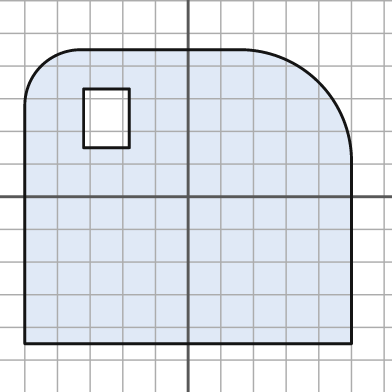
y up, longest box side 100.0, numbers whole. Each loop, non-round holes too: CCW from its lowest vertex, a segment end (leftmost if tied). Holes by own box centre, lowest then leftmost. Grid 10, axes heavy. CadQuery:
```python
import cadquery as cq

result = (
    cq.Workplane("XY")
    .moveTo(-50.0, -45.0)
    .lineTo(50.0, -45.0)
    .lineTo(50.0, 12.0)
    .threePointArc((40.0, 35.0), (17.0, 45.0))
    .lineTo(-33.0, 45.0)
    .threePointArc((-45.0, 40.0), (-50.0, 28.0))
    .close()
    .moveTo(-32.0, 15.0)
    .lineTo(-18.0, 15.0)
    .lineTo(-18.0, 33.0)
    .lineTo(-32.0, 33.0)
    .close()
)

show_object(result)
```